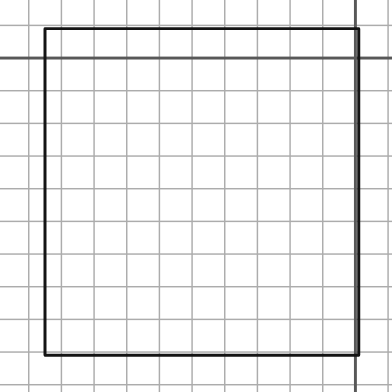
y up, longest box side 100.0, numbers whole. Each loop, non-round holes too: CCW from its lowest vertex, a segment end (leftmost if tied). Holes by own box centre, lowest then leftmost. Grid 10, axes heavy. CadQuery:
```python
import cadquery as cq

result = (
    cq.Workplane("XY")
    .moveTo(-95.0, -91.0)
    .lineTo(1.0, -91.0)
    .lineTo(1.0, 9.0)
    .lineTo(-95.0, 9.0)
    .close()
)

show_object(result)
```